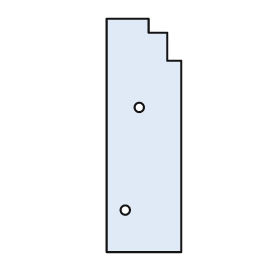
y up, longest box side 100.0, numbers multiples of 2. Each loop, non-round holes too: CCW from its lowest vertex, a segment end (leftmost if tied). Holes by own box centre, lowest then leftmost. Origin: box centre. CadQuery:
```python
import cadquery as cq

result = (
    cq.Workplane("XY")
    .moveTo(-16.0, -50.0)
    .lineTo(16.0, -50.0)
    .lineTo(16.0, 32.0)
    .lineTo(10.0, 32.0)
    .lineTo(10.0, 44.0)
    .lineTo(2.0, 44.0)
    .lineTo(2.0, 50.0)
    .lineTo(-16.0, 50.0)
    .close()
    .moveTo(-8.0, -32.0)
    .circle(2.0)
    .moveTo(-2.0, 12.0)
    .circle(2.0)
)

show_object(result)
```